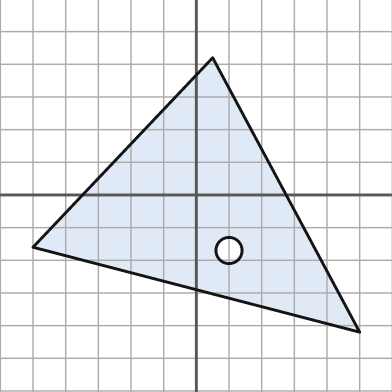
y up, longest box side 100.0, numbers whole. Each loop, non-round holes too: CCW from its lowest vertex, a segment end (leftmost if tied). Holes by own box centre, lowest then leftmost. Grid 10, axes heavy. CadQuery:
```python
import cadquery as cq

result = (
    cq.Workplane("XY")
    .moveTo(50.0, -42.0)
    .lineTo(5.0, 42.0)
    .lineTo(-50.0, -16.0)
    .close()
    .moveTo(10.0, -17.0)
    .circle(4.0)
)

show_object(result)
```